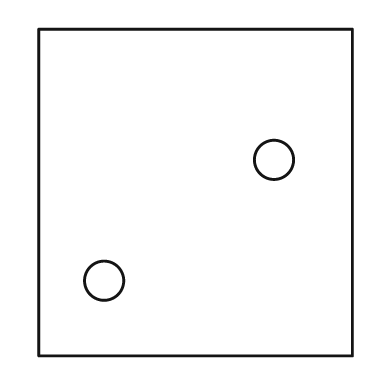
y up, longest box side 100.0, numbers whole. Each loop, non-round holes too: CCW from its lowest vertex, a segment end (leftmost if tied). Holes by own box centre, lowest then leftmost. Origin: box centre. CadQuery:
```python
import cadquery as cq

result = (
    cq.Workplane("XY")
    .moveTo(-48.0, -50.0)
    .lineTo(48.0, -50.0)
    .lineTo(48.0, 50.0)
    .lineTo(-48.0, 50.0)
    .close()
    .moveTo(-28.0, -27.0)
    .circle(6.0)
    .moveTo(24.0, 10.0)
    .circle(6.0)
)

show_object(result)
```